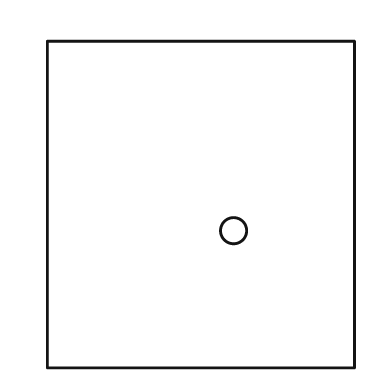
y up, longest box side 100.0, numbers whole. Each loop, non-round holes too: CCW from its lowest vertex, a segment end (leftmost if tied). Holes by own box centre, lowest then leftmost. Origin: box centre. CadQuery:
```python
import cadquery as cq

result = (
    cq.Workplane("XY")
    .moveTo(-47.0, -50.0)
    .lineTo(47.0, -50.0)
    .lineTo(47.0, 50.0)
    .lineTo(-47.0, 50.0)
    .close()
    .moveTo(10.0, -8.0)
    .circle(4.0)
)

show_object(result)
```